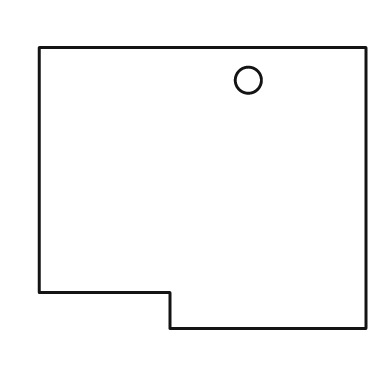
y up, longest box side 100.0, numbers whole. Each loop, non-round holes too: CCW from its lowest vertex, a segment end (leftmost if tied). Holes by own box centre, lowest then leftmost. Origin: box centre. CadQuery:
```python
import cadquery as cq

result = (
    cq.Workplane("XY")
    .moveTo(-10.0, -43.0)
    .lineTo(50.0, -43.0)
    .lineTo(50.0, 43.0)
    .lineTo(-50.0, 43.0)
    .lineTo(-50.0, -32.0)
    .lineTo(-10.0, -32.0)
    .close()
    .moveTo(14.0, 33.0)
    .circle(4.0)
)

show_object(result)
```